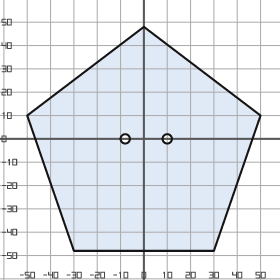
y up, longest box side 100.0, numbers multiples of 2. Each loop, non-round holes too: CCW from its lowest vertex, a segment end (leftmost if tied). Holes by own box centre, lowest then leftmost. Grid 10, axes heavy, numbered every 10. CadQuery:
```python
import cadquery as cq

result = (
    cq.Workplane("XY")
    .moveTo(-30.0, -48.0)
    .lineTo(30.0, -48.0)
    .lineTo(50.0, 10.0)
    .lineTo(0.0, 48.0)
    .lineTo(-50.0, 10.0)
    .close()
    .moveTo(-8.0, 0.0)
    .circle(2.0)
    .moveTo(10.0, 0.0)
    .circle(2.0)
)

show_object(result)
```